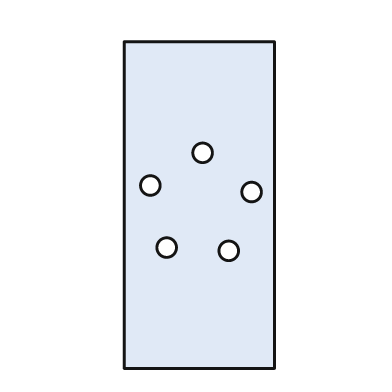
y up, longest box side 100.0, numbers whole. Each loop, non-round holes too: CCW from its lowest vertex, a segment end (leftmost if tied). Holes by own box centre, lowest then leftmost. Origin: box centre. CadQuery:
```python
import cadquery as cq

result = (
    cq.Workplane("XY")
    .moveTo(-23.0, -50.0)
    .lineTo(23.0, -50.0)
    .lineTo(23.0, 50.0)
    .lineTo(-23.0, 50.0)
    .close()
    .moveTo(9.0, -14.0)
    .circle(3.0)
    .moveTo(-10.0, -13.0)
    .circle(3.0)
    .moveTo(16.0, 4.0)
    .circle(3.0)
    .moveTo(-15.0, 6.0)
    .circle(3.0)
    .moveTo(1.0, 16.0)
    .circle(3.0)
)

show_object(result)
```